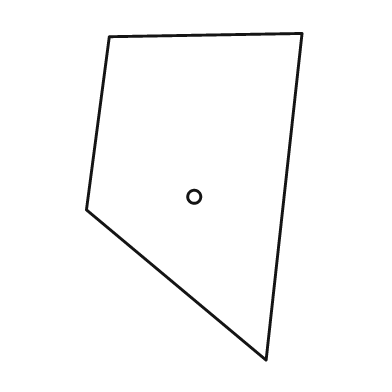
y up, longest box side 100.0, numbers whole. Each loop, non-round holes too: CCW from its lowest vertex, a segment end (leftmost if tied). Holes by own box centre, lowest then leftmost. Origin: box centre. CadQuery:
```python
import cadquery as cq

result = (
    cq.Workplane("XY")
    .moveTo(22.0, -50.0)
    .lineTo(33.0, 50.0)
    .lineTo(-26.0, 49.0)
    .lineTo(-33.0, -4.0)
    .close()
    .moveTo(0.0, 0.0)
    .circle(2.0)
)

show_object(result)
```